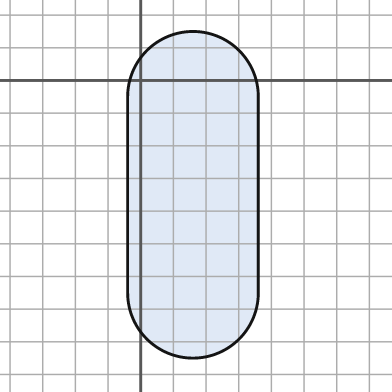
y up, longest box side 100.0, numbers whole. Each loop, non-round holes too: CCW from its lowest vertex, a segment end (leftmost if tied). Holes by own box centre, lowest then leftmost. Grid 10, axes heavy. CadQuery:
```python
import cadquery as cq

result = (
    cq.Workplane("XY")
    .moveTo(-4.0, -65.0)
    .threePointArc((16.0, -85.0), (36.0, -65.0))
    .lineTo(36.0, -5.0)
    .threePointArc((16.0, 15.0), (-4.0, -5.0))
    .close()
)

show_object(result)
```